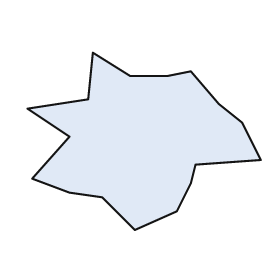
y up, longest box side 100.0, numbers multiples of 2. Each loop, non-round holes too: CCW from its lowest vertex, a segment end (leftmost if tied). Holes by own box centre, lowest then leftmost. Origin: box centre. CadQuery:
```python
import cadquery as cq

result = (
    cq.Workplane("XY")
    .moveTo(-4.0, -38.0)
    .lineTo(14.0, -30.0)
    .lineTo(20.0, -18.0)
    .lineTo(22.0, -10.0)
    .lineTo(50.0, -8.0)
    .lineTo(42.0, 8.0)
    .lineTo(32.0, 16.0)
    .lineTo(20.0, 30.0)
    .lineTo(10.0, 28.0)
    .lineTo(-6.0, 28.0)
    .lineTo(-22.0, 38.0)
    .lineTo(-24.0, 18.0)
    .lineTo(-50.0, 14.0)
    .lineTo(-32.0, 2.0)
    .lineTo(-48.0, -16.0)
    .lineTo(-32.0, -22.0)
    .lineTo(-18.0, -24.0)
    .close()
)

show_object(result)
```